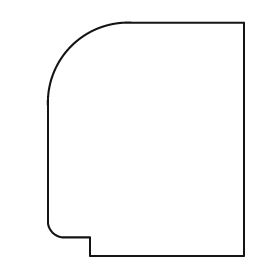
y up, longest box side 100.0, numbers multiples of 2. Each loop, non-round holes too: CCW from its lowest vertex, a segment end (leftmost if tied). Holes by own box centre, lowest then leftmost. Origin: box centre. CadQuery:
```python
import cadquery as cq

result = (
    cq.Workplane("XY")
    .moveTo(-24.0, -50.0)
    .lineTo(42.0, -50.0)
    .lineTo(42.0, 50.0)
    .lineTo(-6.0, 50.0)
    .threePointArc((-32.0, 40.0), (-42.0, 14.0))
    .lineTo(-42.0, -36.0)
    .threePointArc((-40.0, -40.0), (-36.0, -42.0))
    .lineTo(-24.0, -42.0)
    .close()
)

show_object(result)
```